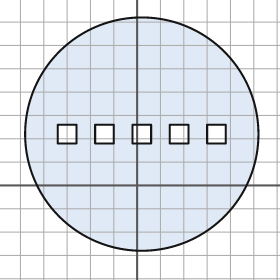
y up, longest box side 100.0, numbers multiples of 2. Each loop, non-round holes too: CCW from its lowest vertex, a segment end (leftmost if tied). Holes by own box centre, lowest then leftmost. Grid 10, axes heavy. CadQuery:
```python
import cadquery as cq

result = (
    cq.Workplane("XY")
    .moveTo(2.0, 22.0)
    .circle(50.0)
    .moveTo(-34.0, 18.0)
    .lineTo(-26.0, 18.0)
    .lineTo(-26.0, 26.0)
    .lineTo(-34.0, 26.0)
    .close()
    .moveTo(-18.0, 18.0)
    .lineTo(-10.0, 18.0)
    .lineTo(-10.0, 26.0)
    .lineTo(-18.0, 26.0)
    .close()
    .moveTo(-2.0, 18.0)
    .lineTo(6.0, 18.0)
    .lineTo(6.0, 26.0)
    .lineTo(-2.0, 26.0)
    .close()
    .moveTo(14.0, 18.0)
    .lineTo(22.0, 18.0)
    .lineTo(22.0, 26.0)
    .lineTo(14.0, 26.0)
    .close()
    .moveTo(30.0, 18.0)
    .lineTo(38.0, 18.0)
    .lineTo(38.0, 26.0)
    .lineTo(30.0, 26.0)
    .close()
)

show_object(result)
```